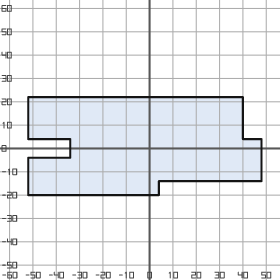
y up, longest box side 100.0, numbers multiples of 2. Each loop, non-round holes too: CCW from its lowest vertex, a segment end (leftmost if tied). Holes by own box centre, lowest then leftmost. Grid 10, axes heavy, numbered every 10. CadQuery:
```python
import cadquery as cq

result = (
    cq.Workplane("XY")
    .moveTo(-52.0, -20.0)
    .lineTo(4.0, -20.0)
    .lineTo(4.0, -14.0)
    .lineTo(48.0, -14.0)
    .lineTo(48.0, 4.0)
    .lineTo(40.0, 4.0)
    .lineTo(40.0, 22.0)
    .lineTo(-52.0, 22.0)
    .lineTo(-52.0, 4.0)
    .lineTo(-34.0, 4.0)
    .lineTo(-34.0, -4.0)
    .lineTo(-52.0, -4.0)
    .close()
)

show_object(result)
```